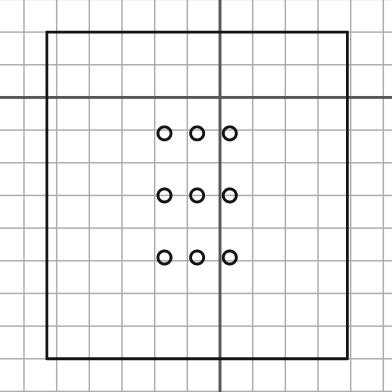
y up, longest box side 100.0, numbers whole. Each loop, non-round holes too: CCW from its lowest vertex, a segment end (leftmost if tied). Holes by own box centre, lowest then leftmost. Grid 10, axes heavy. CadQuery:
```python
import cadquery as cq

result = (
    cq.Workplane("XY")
    .moveTo(-53.0, -80.0)
    .lineTo(39.0, -80.0)
    .lineTo(39.0, 20.0)
    .lineTo(-53.0, 20.0)
    .close()
    .moveTo(-17.0, -49.0)
    .circle(2.0)
    .moveTo(-7.0, -49.0)
    .circle(2.0)
    .moveTo(3.0, -49.0)
    .circle(2.0)
    .moveTo(-17.0, -30.0)
    .circle(2.0)
    .moveTo(-7.0, -30.0)
    .circle(2.0)
    .moveTo(3.0, -30.0)
    .circle(2.0)
    .moveTo(-17.0, -11.0)
    .circle(2.0)
    .moveTo(-7.0, -11.0)
    .circle(2.0)
    .moveTo(3.0, -11.0)
    .circle(2.0)
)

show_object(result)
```